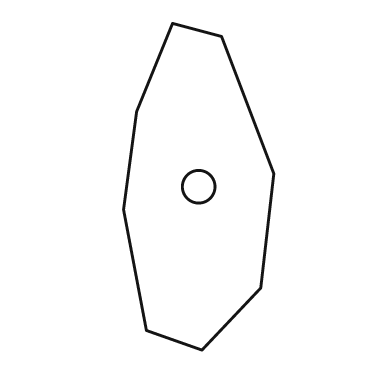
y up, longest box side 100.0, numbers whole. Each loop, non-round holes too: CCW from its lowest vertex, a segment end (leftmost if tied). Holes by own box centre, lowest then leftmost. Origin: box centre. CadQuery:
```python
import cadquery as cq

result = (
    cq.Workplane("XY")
    .moveTo(1.0, -50.0)
    .lineTo(19.0, -31.0)
    .lineTo(23.0, 4.0)
    .lineTo(7.0, 46.0)
    .lineTo(-8.0, 50.0)
    .lineTo(-19.0, 23.0)
    .lineTo(-23.0, -7.0)
    .lineTo(-16.0, -44.0)
    .close()
    .moveTo(0.0, 0.0)
    .circle(5.0)
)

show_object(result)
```